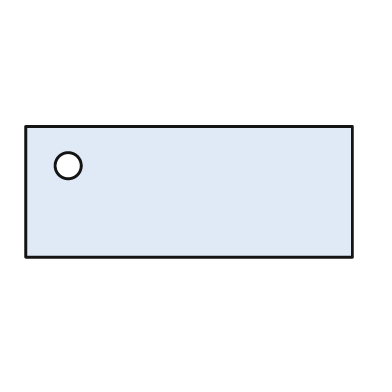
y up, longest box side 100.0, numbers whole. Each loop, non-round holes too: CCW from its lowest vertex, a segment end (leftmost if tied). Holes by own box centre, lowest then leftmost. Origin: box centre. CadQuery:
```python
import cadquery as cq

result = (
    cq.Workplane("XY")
    .moveTo(-50.0, -20.0)
    .lineTo(50.0, -20.0)
    .lineTo(50.0, 20.0)
    .lineTo(-50.0, 20.0)
    .close()
    .moveTo(-37.0, 8.0)
    .circle(4.0)
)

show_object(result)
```